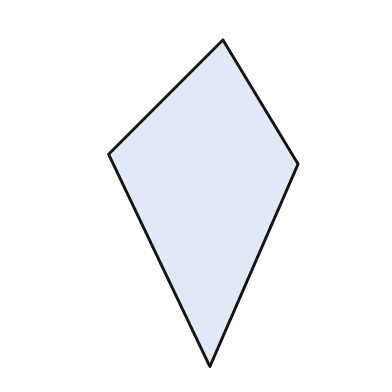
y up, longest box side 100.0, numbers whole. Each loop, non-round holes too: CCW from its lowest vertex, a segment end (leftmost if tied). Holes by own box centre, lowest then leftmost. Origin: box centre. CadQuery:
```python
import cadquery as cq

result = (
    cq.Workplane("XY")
    .moveTo(2.0, -50.0)
    .lineTo(29.0, 12.0)
    .lineTo(6.0, 50.0)
    .lineTo(-29.0, 15.0)
    .close()
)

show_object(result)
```